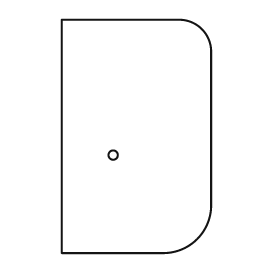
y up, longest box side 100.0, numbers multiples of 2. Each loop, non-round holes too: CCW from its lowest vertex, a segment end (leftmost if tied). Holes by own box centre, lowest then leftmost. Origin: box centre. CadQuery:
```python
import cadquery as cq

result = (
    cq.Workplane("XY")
    .moveTo(-32.0, -50.0)
    .lineTo(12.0, -50.0)
    .threePointArc((26.0, -44.0), (32.0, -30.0))
    .lineTo(32.0, 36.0)
    .threePointArc((28.0, 46.0), (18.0, 50.0))
    .lineTo(-32.0, 50.0)
    .close()
    .moveTo(-10.0, -8.0)
    .circle(2.0)
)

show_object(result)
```